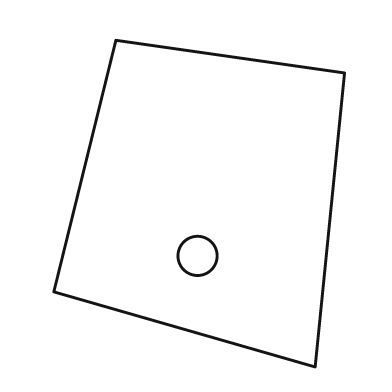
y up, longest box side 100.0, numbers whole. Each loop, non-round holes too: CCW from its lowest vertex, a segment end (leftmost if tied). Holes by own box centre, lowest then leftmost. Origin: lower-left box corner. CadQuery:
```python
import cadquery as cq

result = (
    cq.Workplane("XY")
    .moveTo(80.0, 0.0)
    .lineTo(89.0, 90.0)
    .lineTo(19.0, 100.0)
    .lineTo(0.0, 23.0)
    .close()
    .moveTo(44.0, 34.0)
    .circle(6.0)
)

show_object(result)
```